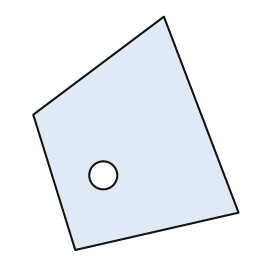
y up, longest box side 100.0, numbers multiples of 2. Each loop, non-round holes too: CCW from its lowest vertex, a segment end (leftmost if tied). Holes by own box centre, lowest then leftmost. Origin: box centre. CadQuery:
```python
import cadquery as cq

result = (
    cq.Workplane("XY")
    .moveTo(-26.0, -50.0)
    .lineTo(44.0, -34.0)
    .lineTo(12.0, 50.0)
    .lineTo(-44.0, 8.0)
    .close()
    .moveTo(-14.0, -18.0)
    .circle(6.0)
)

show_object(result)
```